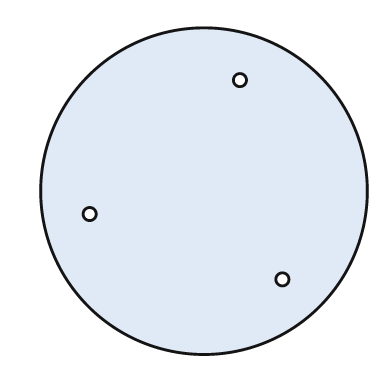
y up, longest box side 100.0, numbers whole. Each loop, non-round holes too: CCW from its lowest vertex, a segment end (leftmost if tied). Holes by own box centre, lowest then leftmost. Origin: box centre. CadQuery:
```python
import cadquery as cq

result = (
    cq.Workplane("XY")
    .moveTo(0.0, 0.0)
    .circle(50.0)
    .moveTo(24.0, -27.0)
    .circle(2.0)
    .moveTo(-35.0, -7.0)
    .circle(2.0)
    .moveTo(11.0, 34.0)
    .circle(2.0)
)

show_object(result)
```